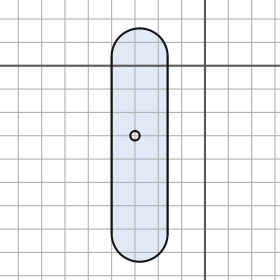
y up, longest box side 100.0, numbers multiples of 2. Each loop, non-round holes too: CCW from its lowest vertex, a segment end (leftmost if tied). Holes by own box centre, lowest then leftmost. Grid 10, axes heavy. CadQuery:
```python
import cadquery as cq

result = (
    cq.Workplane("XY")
    .moveTo(-40.0, -72.0)
    .threePointArc((-28.0, -84.0), (-16.0, -72.0))
    .lineTo(-16.0, 4.0)
    .threePointArc((-28.0, 16.0), (-40.0, 4.0))
    .close()
    .moveTo(-30.0, -30.0)
    .circle(2.0)
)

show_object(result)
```